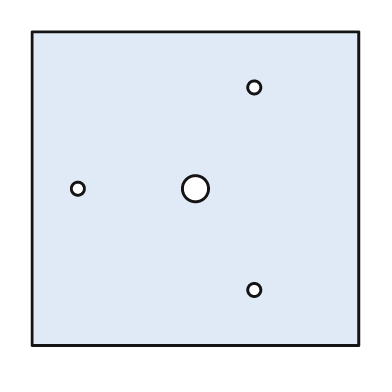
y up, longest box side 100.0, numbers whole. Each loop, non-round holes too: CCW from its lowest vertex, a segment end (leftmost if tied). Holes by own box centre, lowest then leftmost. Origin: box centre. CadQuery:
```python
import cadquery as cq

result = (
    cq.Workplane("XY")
    .moveTo(-50.0, -48.0)
    .lineTo(50.0, -48.0)
    .lineTo(50.0, 48.0)
    .lineTo(-50.0, 48.0)
    .close()
    .moveTo(18.0, -31.0)
    .circle(2.0)
    .moveTo(-36.0, 0.0)
    .circle(2.0)
    .moveTo(0.0, 0.0)
    .circle(4.0)
    .moveTo(18.0, 31.0)
    .circle(2.0)
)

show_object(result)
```